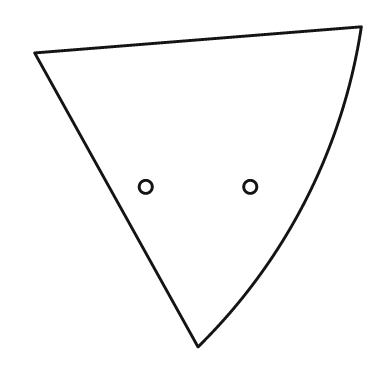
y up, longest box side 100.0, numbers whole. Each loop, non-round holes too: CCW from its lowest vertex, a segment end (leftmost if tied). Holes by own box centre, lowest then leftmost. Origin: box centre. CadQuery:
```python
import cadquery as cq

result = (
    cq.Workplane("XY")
    .moveTo(0.0, -49.0)
    .threePointArc((33.0, -4.0), (50.0, 49.0))
    .lineTo(-50.0, 41.0)
    .close()
    .moveTo(-16.0, 0.0)
    .circle(2.0)
    .moveTo(16.0, 0.0)
    .circle(2.0)
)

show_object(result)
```